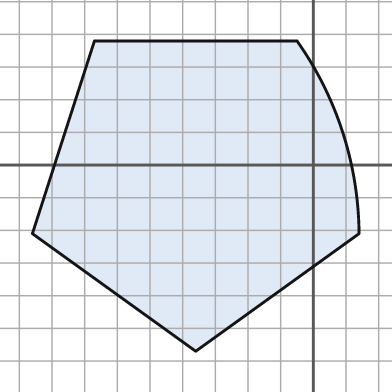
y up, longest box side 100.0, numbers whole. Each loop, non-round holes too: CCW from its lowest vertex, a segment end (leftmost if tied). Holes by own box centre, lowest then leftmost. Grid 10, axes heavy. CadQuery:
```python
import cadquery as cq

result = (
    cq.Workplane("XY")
    .moveTo(-36.0, -57.0)
    .lineTo(14.0, -21.0)
    .threePointArc((9.0, 10.0), (-5.0, 38.0))
    .lineTo(-67.0, 38.0)
    .lineTo(-86.0, -21.0)
    .close()
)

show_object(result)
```